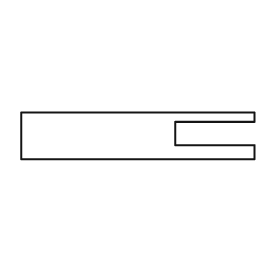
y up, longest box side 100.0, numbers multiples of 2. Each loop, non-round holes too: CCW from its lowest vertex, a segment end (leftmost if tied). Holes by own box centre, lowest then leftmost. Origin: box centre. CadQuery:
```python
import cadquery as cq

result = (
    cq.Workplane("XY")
    .moveTo(-50.0, -10.0)
    .lineTo(50.0, -10.0)
    .lineTo(50.0, -4.0)
    .lineTo(16.0, -4.0)
    .lineTo(16.0, 6.0)
    .lineTo(50.0, 6.0)
    .lineTo(50.0, 10.0)
    .lineTo(-50.0, 10.0)
    .close()
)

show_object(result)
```